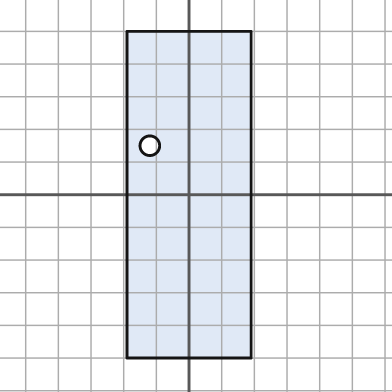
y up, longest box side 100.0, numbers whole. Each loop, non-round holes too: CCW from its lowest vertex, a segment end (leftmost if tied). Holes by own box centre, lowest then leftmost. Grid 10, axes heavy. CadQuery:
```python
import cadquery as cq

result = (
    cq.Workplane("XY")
    .moveTo(-19.0, -50.0)
    .lineTo(19.0, -50.0)
    .lineTo(19.0, 50.0)
    .lineTo(-19.0, 50.0)
    .close()
    .moveTo(-12.0, 15.0)
    .circle(3.0)
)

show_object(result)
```